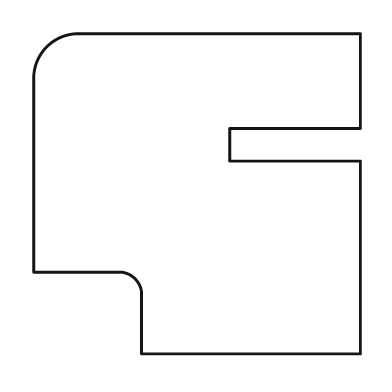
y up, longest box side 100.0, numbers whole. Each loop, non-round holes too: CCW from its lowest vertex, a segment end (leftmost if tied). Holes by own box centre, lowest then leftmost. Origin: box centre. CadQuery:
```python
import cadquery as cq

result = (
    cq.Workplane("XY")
    .moveTo(-17.0, -49.0)
    .lineTo(50.0, -49.0)
    .lineTo(50.0, 10.0)
    .lineTo(10.0, 10.0)
    .lineTo(10.0, 20.0)
    .lineTo(50.0, 20.0)
    .lineTo(50.0, 49.0)
    .lineTo(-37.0, 49.0)
    .threePointArc((-46.0, 45.0), (-50.0, 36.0))
    .lineTo(-50.0, -24.0)
    .lineTo(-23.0, -24.0)
    .threePointArc((-19.0, -26.0), (-17.0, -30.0))
    .close()
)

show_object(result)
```